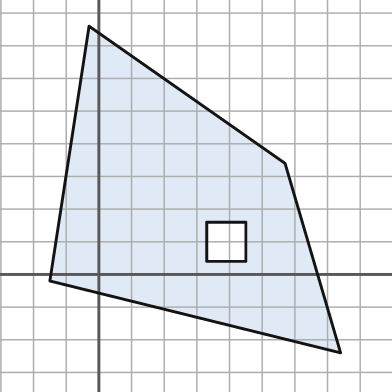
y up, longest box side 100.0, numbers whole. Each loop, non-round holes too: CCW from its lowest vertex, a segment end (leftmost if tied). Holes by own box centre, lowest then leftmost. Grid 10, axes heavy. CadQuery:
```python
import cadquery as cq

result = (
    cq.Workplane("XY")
    .moveTo(74.0, -24.0)
    .lineTo(57.0, 34.0)
    .lineTo(-3.0, 76.0)
    .lineTo(-15.0, -2.0)
    .close()
    .moveTo(33.0, 4.0)
    .lineTo(45.0, 4.0)
    .lineTo(45.0, 16.0)
    .lineTo(33.0, 16.0)
    .close()
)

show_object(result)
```